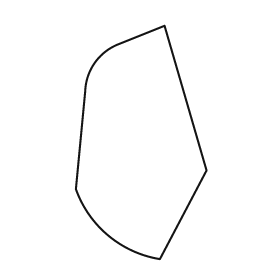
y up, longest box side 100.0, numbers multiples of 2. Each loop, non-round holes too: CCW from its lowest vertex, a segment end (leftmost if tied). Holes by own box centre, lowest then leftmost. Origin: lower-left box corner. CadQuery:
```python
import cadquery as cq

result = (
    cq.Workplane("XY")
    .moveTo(36.0, 0.0)
    .lineTo(56.0, 38.0)
    .lineTo(38.0, 100.0)
    .lineTo(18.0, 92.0)
    .threePointArc((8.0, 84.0), (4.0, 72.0))
    .lineTo(0.0, 30.0)
    .threePointArc((14.0, 10.0), (36.0, 0.0))
    .close()
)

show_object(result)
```